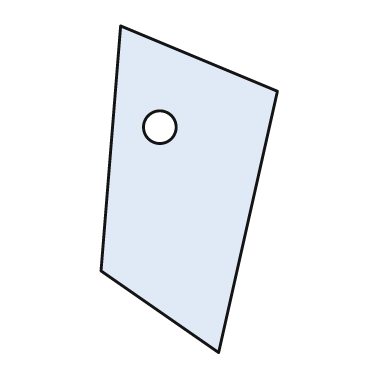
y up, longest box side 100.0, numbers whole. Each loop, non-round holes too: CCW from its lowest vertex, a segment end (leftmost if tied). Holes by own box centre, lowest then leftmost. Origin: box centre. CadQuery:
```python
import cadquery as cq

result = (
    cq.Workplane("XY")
    .moveTo(9.0, -50.0)
    .lineTo(27.0, 30.0)
    .lineTo(-21.0, 50.0)
    .lineTo(-27.0, -25.0)
    .close()
    .moveTo(-9.0, 19.0)
    .circle(5.0)
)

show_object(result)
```